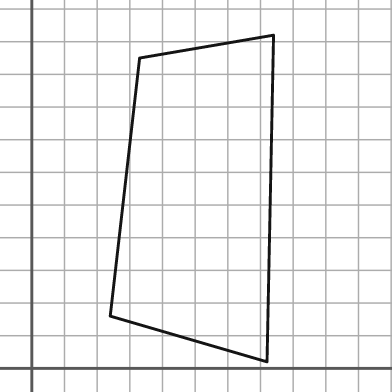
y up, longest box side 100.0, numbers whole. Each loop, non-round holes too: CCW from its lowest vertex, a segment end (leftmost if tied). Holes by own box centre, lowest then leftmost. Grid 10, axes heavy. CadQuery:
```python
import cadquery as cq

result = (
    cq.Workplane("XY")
    .moveTo(72.0, 2.0)
    .lineTo(74.0, 102.0)
    .lineTo(33.0, 95.0)
    .lineTo(24.0, 16.0)
    .close()
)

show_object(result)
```